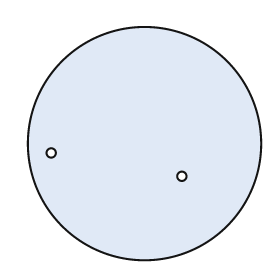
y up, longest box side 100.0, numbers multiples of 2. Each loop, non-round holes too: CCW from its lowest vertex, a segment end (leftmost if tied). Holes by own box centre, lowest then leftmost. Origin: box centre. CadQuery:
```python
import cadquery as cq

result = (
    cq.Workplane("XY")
    .moveTo(0.0, 0.0)
    .circle(50.0)
    .moveTo(16.0, -14.0)
    .circle(2.0)
    .moveTo(-40.0, -4.0)
    .circle(2.0)
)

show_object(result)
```